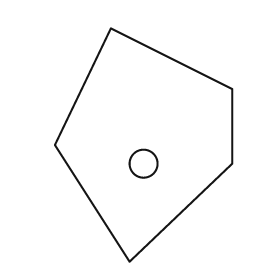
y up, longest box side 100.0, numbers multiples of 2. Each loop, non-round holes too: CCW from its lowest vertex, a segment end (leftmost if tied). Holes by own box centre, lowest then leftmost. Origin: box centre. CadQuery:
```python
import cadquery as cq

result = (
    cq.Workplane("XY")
    .moveTo(-6.0, -50.0)
    .lineTo(38.0, -8.0)
    .lineTo(38.0, 24.0)
    .lineTo(-14.0, 50.0)
    .lineTo(-38.0, 0.0)
    .close()
    .moveTo(0.0, -8.0)
    .circle(6.0)
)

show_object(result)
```